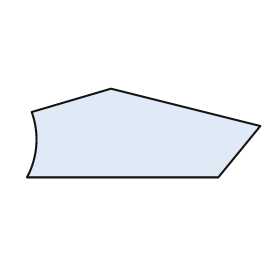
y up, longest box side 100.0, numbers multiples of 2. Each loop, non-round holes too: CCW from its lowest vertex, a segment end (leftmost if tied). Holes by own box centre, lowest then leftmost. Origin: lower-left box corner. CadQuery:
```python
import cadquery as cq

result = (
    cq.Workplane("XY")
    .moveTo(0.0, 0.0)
    .lineTo(82.0, 0.0)
    .lineTo(100.0, 22.0)
    .lineTo(36.0, 38.0)
    .lineTo(2.0, 28.0)
    .threePointArc((4.0, 14.0), (0.0, 0.0))
    .close()
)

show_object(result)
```